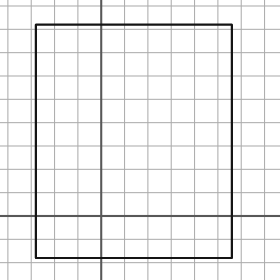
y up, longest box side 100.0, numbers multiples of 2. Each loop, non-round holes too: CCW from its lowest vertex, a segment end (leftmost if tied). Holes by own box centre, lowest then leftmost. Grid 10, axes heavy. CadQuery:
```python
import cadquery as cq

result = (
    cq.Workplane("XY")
    .moveTo(-28.0, -18.0)
    .lineTo(56.0, -18.0)
    .lineTo(56.0, 82.0)
    .lineTo(-28.0, 82.0)
    .close()
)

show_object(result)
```